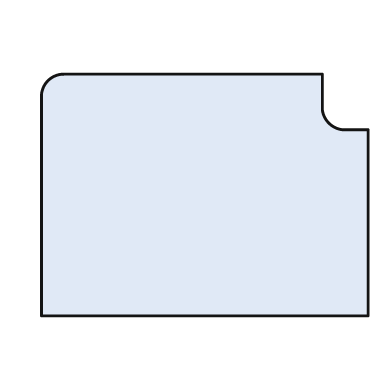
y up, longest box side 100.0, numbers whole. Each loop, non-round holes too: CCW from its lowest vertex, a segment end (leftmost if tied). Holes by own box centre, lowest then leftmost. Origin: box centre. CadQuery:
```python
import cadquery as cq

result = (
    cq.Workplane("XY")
    .moveTo(-50.0, -37.0)
    .lineTo(50.0, -37.0)
    .lineTo(50.0, 20.0)
    .lineTo(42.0, 20.0)
    .threePointArc((38.0, 22.0), (36.0, 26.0))
    .lineTo(36.0, 37.0)
    .lineTo(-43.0, 37.0)
    .threePointArc((-48.0, 35.0), (-50.0, 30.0))
    .close()
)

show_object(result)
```